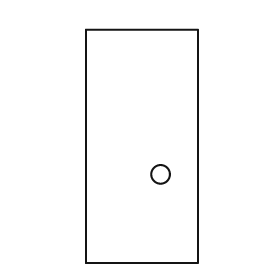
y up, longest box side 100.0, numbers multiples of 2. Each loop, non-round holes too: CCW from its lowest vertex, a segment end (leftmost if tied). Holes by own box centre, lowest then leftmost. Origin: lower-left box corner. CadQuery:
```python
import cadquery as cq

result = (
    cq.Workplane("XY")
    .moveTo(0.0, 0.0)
    .lineTo(48.0, 0.0)
    .lineTo(48.0, 100.0)
    .lineTo(0.0, 100.0)
    .close()
    .moveTo(32.0, 38.0)
    .circle(4.0)
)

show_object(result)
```